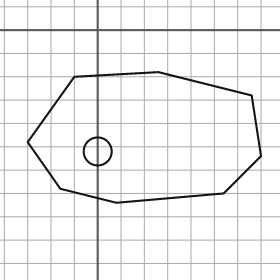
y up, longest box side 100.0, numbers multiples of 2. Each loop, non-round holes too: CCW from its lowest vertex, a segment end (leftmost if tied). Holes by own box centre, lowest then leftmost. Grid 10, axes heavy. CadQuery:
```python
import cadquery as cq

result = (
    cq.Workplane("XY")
    .moveTo(8.0, -74.0)
    .lineTo(54.0, -70.0)
    .lineTo(70.0, -54.0)
    .lineTo(66.0, -28.0)
    .lineTo(26.0, -18.0)
    .lineTo(-10.0, -20.0)
    .lineTo(-30.0, -48.0)
    .lineTo(-16.0, -68.0)
    .close()
    .moveTo(0.0, -52.0)
    .circle(6.0)
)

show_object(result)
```